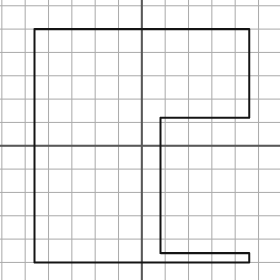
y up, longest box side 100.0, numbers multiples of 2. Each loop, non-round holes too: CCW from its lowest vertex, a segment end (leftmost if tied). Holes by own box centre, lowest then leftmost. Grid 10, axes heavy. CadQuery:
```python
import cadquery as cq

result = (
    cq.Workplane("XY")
    .moveTo(-46.0, -50.0)
    .lineTo(46.0, -50.0)
    .lineTo(46.0, -46.0)
    .lineTo(8.0, -46.0)
    .lineTo(8.0, 12.0)
    .lineTo(46.0, 12.0)
    .lineTo(46.0, 50.0)
    .lineTo(-46.0, 50.0)
    .close()
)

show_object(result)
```